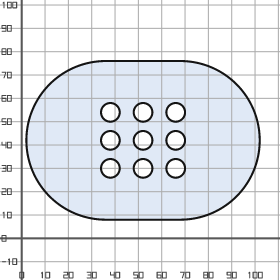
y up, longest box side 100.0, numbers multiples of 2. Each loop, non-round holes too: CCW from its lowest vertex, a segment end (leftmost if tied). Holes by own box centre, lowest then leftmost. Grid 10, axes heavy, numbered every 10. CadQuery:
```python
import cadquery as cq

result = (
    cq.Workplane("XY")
    .moveTo(36.0, 8.0)
    .lineTo(68.0, 8.0)
    .threePointArc((102.0, 42.0), (68.0, 76.0))
    .lineTo(36.0, 76.0)
    .threePointArc((2.0, 42.0), (36.0, 8.0))
    .close()
    .moveTo(38.0, 30.0)
    .circle(4.0)
    .moveTo(52.0, 30.0)
    .circle(4.0)
    .moveTo(66.0, 30.0)
    .circle(4.0)
    .moveTo(38.0, 42.0)
    .circle(4.0)
    .moveTo(52.0, 42.0)
    .circle(4.0)
    .moveTo(66.0, 42.0)
    .circle(4.0)
    .moveTo(38.0, 54.0)
    .circle(4.0)
    .moveTo(52.0, 54.0)
    .circle(4.0)
    .moveTo(66.0, 54.0)
    .circle(4.0)
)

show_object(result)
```